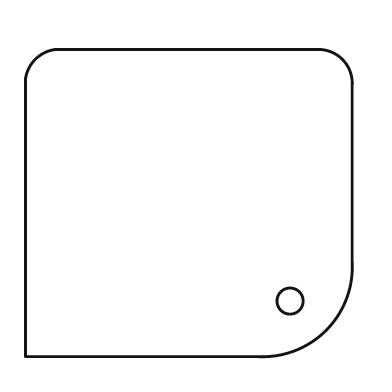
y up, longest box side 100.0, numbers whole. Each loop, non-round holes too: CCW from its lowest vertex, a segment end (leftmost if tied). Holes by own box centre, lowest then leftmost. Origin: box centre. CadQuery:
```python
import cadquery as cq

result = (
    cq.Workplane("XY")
    .moveTo(-50.0, -47.0)
    .lineTo(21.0, -47.0)
    .threePointArc((42.0, -39.0), (50.0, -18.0))
    .lineTo(50.0, 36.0)
    .threePointArc((47.0, 44.0), (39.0, 47.0))
    .lineTo(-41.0, 47.0)
    .threePointArc((-47.0, 44.0), (-50.0, 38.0))
    .close()
    .moveTo(31.0, -30.0)
    .circle(4.0)
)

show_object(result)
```